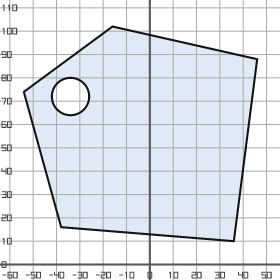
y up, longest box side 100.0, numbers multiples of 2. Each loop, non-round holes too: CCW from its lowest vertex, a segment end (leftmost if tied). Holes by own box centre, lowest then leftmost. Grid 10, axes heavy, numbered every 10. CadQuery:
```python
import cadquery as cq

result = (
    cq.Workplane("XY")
    .moveTo(36.0, 10.0)
    .lineTo(46.0, 88.0)
    .lineTo(-16.0, 102.0)
    .lineTo(-54.0, 74.0)
    .lineTo(-38.0, 16.0)
    .close()
    .moveTo(-34.0, 72.0)
    .circle(8.0)
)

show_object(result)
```